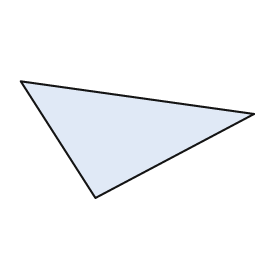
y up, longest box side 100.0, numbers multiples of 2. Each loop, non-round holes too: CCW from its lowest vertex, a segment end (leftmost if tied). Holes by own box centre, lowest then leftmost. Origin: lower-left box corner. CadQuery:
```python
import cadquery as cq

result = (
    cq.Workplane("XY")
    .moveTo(32.0, 0.0)
    .lineTo(100.0, 36.0)
    .lineTo(0.0, 50.0)
    .close()
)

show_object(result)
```